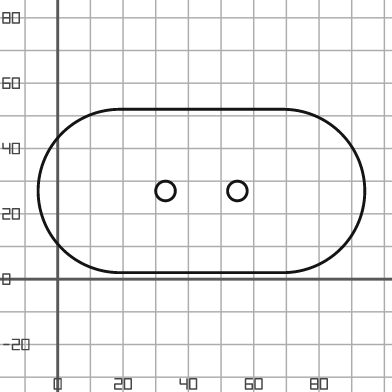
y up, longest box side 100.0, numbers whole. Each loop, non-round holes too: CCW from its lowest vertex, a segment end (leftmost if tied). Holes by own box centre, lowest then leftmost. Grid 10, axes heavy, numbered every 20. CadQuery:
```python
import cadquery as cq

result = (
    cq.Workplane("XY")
    .moveTo(19.0, 2.0)
    .lineTo(69.0, 2.0)
    .threePointArc((94.0, 27.0), (69.0, 52.0))
    .lineTo(19.0, 52.0)
    .threePointArc((-6.0, 27.0), (19.0, 2.0))
    .close()
    .moveTo(33.0, 27.0)
    .circle(3.0)
    .moveTo(55.0, 27.0)
    .circle(3.0)
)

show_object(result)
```